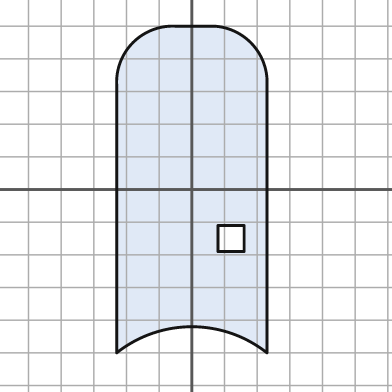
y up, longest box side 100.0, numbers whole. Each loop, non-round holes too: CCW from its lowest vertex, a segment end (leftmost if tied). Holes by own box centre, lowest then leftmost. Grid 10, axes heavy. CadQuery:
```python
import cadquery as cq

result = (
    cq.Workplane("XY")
    .moveTo(-23.0, -50.0)
    .threePointArc((0.0, -42.0), (23.0, -50.0))
    .lineTo(23.0, 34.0)
    .threePointArc((18.0, 45.0), (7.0, 50.0))
    .lineTo(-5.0, 50.0)
    .threePointArc((-18.0, 45.0), (-23.0, 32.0))
    .close()
    .moveTo(8.0, -19.0)
    .lineTo(16.0, -19.0)
    .lineTo(16.0, -11.0)
    .lineTo(8.0, -11.0)
    .close()
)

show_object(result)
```